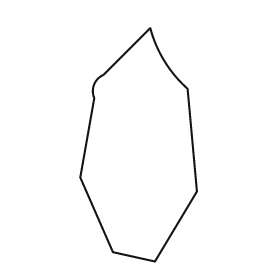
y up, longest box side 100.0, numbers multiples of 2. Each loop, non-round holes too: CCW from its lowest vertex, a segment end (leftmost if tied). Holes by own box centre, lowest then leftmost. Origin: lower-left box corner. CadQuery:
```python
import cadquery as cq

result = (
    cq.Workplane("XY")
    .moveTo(32.0, 0.0)
    .lineTo(50.0, 30.0)
    .lineTo(46.0, 74.0)
    .threePointArc((36.0, 86.0), (30.0, 100.0))
    .lineTo(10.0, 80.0)
    .threePointArc((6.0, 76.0), (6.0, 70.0))
    .lineTo(0.0, 36.0)
    .lineTo(14.0, 4.0)
    .close()
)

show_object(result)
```